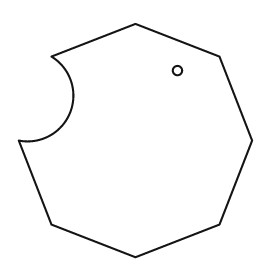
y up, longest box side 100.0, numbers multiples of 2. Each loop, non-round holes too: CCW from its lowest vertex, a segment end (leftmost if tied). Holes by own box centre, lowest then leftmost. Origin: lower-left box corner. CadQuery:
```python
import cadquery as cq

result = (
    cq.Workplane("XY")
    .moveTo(50.0, 0.0)
    .lineTo(86.0, 14.0)
    .lineTo(100.0, 50.0)
    .lineTo(86.0, 86.0)
    .lineTo(50.0, 100.0)
    .lineTo(14.0, 86.0)
    .threePointArc((22.0, 62.0), (0.0, 50.0))
    .lineTo(14.0, 14.0)
    .close()
    .moveTo(68.0, 80.0)
    .circle(2.0)
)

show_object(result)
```